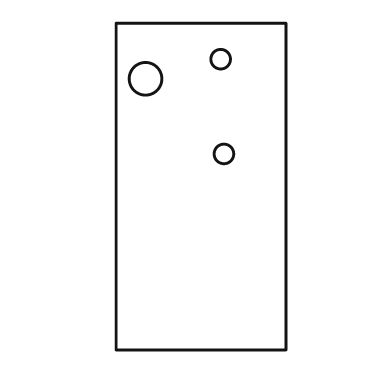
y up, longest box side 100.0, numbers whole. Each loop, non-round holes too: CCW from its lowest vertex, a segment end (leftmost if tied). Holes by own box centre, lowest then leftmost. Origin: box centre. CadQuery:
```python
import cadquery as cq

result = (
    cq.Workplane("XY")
    .moveTo(-26.0, -50.0)
    .lineTo(26.0, -50.0)
    .lineTo(26.0, 50.0)
    .lineTo(-26.0, 50.0)
    .close()
    .moveTo(7.0, 10.0)
    .circle(3.0)
    .moveTo(-17.0, 33.0)
    .circle(5.0)
    .moveTo(6.0, 39.0)
    .circle(3.0)
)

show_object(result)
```